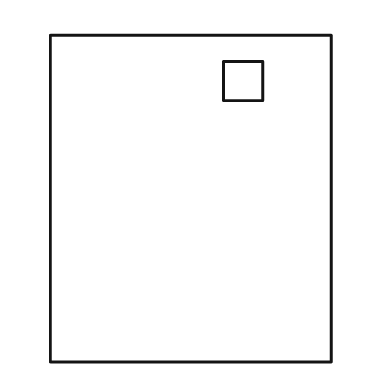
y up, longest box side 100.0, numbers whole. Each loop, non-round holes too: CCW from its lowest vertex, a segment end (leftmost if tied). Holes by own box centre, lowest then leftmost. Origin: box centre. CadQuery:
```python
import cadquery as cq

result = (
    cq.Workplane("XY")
    .moveTo(-43.0, -50.0)
    .lineTo(43.0, -50.0)
    .lineTo(43.0, 50.0)
    .lineTo(-43.0, 50.0)
    .close()
    .moveTo(10.0, 30.0)
    .lineTo(22.0, 30.0)
    .lineTo(22.0, 42.0)
    .lineTo(10.0, 42.0)
    .close()
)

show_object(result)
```